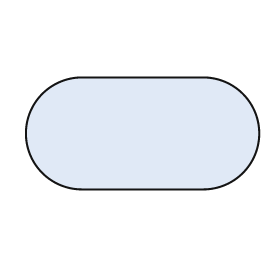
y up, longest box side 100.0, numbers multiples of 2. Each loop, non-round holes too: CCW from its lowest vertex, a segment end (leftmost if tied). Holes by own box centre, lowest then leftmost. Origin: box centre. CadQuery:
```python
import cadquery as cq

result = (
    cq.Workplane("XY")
    .moveTo(-26.0, -24.0)
    .lineTo(26.0, -24.0)
    .threePointArc((50.0, 0.0), (26.0, 24.0))
    .lineTo(-26.0, 24.0)
    .threePointArc((-50.0, 0.0), (-26.0, -24.0))
    .close()
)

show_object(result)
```